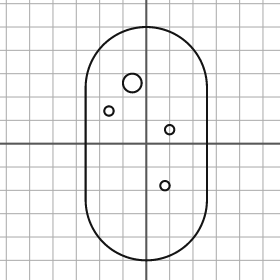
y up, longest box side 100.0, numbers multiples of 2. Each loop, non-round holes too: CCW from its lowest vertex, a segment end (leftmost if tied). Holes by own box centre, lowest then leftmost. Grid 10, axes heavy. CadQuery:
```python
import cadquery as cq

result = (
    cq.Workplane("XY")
    .moveTo(-26.0, -24.0)
    .threePointArc((0.0, -50.0), (26.0, -24.0))
    .lineTo(26.0, 24.0)
    .threePointArc((0.0, 50.0), (-26.0, 24.0))
    .close()
    .moveTo(8.0, -18.0)
    .circle(2.0)
    .moveTo(10.0, 6.0)
    .circle(2.0)
    .moveTo(-16.0, 14.0)
    .circle(2.0)
    .moveTo(-6.0, 26.0)
    .circle(4.0)
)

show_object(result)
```